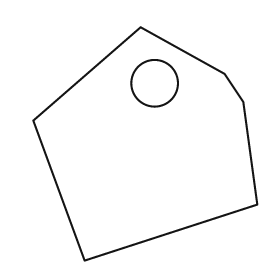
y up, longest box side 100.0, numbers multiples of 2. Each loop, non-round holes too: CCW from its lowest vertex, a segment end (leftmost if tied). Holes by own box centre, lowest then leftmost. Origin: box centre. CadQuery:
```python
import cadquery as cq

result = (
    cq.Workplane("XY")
    .moveTo(-26.0, -50.0)
    .lineTo(48.0, -26.0)
    .lineTo(42.0, 18.0)
    .lineTo(34.0, 30.0)
    .lineTo(-2.0, 50.0)
    .lineTo(-48.0, 10.0)
    .close()
    .moveTo(4.0, 26.0)
    .circle(10.0)
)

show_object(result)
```